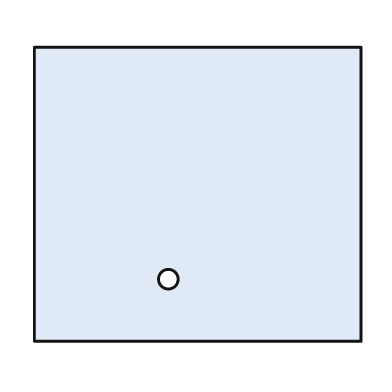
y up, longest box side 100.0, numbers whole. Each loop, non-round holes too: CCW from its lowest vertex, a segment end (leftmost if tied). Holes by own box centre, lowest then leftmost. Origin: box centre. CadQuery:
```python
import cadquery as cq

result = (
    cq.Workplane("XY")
    .moveTo(-50.0, -45.0)
    .lineTo(50.0, -45.0)
    .lineTo(50.0, 45.0)
    .lineTo(-50.0, 45.0)
    .close()
    .moveTo(-9.0, -26.0)
    .circle(3.0)
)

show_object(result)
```